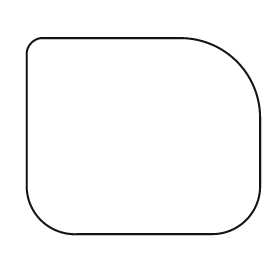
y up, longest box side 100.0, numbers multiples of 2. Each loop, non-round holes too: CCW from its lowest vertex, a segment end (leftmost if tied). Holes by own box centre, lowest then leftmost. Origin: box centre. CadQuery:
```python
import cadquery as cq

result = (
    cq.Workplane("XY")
    .moveTo(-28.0, -42.0)
    .lineTo(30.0, -42.0)
    .threePointArc((44.0, -36.0), (50.0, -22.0))
    .lineTo(50.0, 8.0)
    .threePointArc((40.0, 32.0), (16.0, 42.0))
    .lineTo(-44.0, 42.0)
    .threePointArc((-48.0, 40.0), (-50.0, 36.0))
    .lineTo(-50.0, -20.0)
    .threePointArc((-44.0, -36.0), (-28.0, -42.0))
    .close()
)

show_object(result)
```